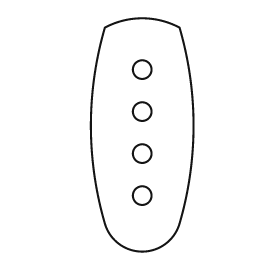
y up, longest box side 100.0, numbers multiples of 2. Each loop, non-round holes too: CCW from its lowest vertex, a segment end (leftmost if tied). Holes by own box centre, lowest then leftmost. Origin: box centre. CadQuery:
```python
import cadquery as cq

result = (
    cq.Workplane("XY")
    .moveTo(-16.0, -38.0)
    .threePointArc((0.0, -50.0), (16.0, -38.0))
    .threePointArc((22.0, 4.0), (16.0, 46.0))
    .threePointArc((0.0, 50.0), (-16.0, 46.0))
    .threePointArc((-22.0, 4.0), (-16.0, -38.0))
    .close()
    .moveTo(0.0, -26.0)
    .circle(4.0)
    .moveTo(0.0, -8.0)
    .circle(4.0)
    .moveTo(0.0, 10.0)
    .circle(4.0)
    .moveTo(0.0, 28.0)
    .circle(4.0)
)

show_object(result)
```